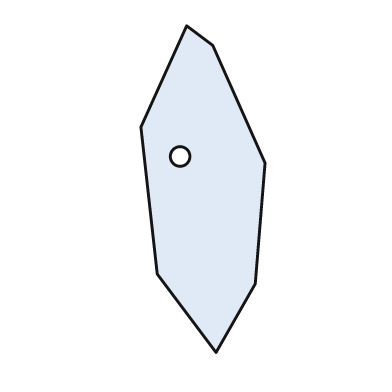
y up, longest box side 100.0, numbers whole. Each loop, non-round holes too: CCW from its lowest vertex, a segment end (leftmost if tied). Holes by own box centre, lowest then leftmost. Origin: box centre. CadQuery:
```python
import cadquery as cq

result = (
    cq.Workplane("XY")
    .moveTo(4.0, -50.0)
    .lineTo(16.0, -29.0)
    .lineTo(19.0, 8.0)
    .lineTo(3.0, 44.0)
    .lineTo(-5.0, 50.0)
    .lineTo(-19.0, 19.0)
    .lineTo(-14.0, -26.0)
    .close()
    .moveTo(-7.0, 10.0)
    .circle(3.0)
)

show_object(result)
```